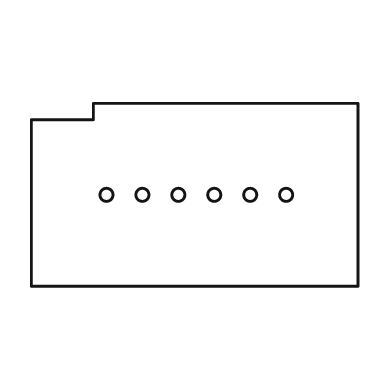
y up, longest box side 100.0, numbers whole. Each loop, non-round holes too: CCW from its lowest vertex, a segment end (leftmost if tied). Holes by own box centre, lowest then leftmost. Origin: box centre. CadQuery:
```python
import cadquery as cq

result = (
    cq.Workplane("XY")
    .moveTo(-50.0, -28.0)
    .lineTo(50.0, -28.0)
    .lineTo(50.0, 28.0)
    .lineTo(-31.0, 28.0)
    .lineTo(-31.0, 23.0)
    .lineTo(-50.0, 23.0)
    .close()
    .moveTo(-27.0, 0.0)
    .circle(2.0)
    .moveTo(-16.0, 0.0)
    .circle(2.0)
    .moveTo(-5.0, 0.0)
    .circle(2.0)
    .moveTo(6.0, 0.0)
    .circle(2.0)
    .moveTo(17.0, 0.0)
    .circle(2.0)
    .moveTo(28.0, 0.0)
    .circle(2.0)
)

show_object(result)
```